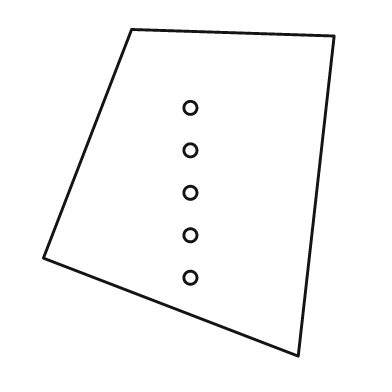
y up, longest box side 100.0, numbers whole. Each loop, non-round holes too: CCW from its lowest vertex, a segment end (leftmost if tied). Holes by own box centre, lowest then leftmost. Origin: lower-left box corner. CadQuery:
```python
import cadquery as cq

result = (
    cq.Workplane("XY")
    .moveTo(78.0, 0.0)
    .lineTo(89.0, 98.0)
    .lineTo(27.0, 100.0)
    .lineTo(0.0, 30.0)
    .close()
    .moveTo(45.0, 24.0)
    .circle(2.0)
    .moveTo(45.0, 37.0)
    .circle(2.0)
    .moveTo(45.0, 50.0)
    .circle(2.0)
    .moveTo(45.0, 63.0)
    .circle(2.0)
    .moveTo(45.0, 76.0)
    .circle(2.0)
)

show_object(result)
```